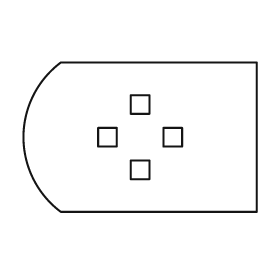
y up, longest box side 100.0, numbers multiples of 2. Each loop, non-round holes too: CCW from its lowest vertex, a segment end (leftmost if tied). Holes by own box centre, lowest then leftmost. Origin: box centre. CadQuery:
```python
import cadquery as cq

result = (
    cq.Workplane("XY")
    .moveTo(-34.0, -32.0)
    .lineTo(50.0, -32.0)
    .lineTo(50.0, 32.0)
    .lineTo(-34.0, 32.0)
    .threePointArc((-50.0, 0.0), (-34.0, -32.0))
    .close()
    .moveTo(-4.0, -18.0)
    .lineTo(4.0, -18.0)
    .lineTo(4.0, -10.0)
    .lineTo(-4.0, -10.0)
    .close()
    .moveTo(-18.0, -4.0)
    .lineTo(-10.0, -4.0)
    .lineTo(-10.0, 4.0)
    .lineTo(-18.0, 4.0)
    .close()
    .moveTo(10.0, -4.0)
    .lineTo(18.0, -4.0)
    .lineTo(18.0, 4.0)
    .lineTo(10.0, 4.0)
    .close()
    .moveTo(-4.0, 10.0)
    .lineTo(4.0, 10.0)
    .lineTo(4.0, 18.0)
    .lineTo(-4.0, 18.0)
    .close()
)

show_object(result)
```